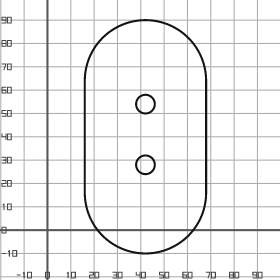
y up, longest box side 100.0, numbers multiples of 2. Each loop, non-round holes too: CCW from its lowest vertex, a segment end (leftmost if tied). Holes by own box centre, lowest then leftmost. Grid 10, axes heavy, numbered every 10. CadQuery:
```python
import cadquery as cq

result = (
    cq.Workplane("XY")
    .moveTo(16.0, 16.0)
    .threePointArc((42.0, -10.0), (68.0, 16.0))
    .lineTo(68.0, 64.0)
    .threePointArc((42.0, 90.0), (16.0, 64.0))
    .close()
    .moveTo(42.0, 28.0)
    .circle(4.0)
    .moveTo(42.0, 54.0)
    .circle(4.0)
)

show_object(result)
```